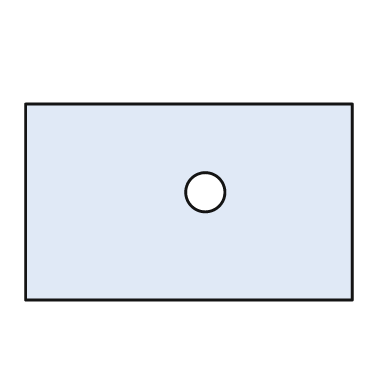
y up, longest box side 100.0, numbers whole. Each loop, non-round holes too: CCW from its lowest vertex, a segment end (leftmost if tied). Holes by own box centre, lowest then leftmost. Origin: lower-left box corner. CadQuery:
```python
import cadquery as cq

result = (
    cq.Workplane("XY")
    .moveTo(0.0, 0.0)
    .lineTo(100.0, 0.0)
    .lineTo(100.0, 60.0)
    .lineTo(0.0, 60.0)
    .close()
    .moveTo(55.0, 33.0)
    .circle(6.0)
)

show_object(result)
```